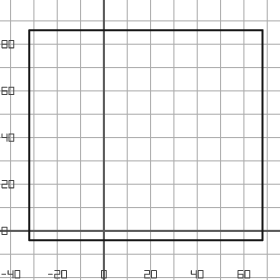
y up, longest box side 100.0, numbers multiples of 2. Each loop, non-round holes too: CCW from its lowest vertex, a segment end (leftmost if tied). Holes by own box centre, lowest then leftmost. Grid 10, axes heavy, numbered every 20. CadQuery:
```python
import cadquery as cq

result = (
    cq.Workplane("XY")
    .moveTo(-32.0, -4.0)
    .lineTo(68.0, -4.0)
    .lineTo(68.0, 86.0)
    .lineTo(-32.0, 86.0)
    .close()
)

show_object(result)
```